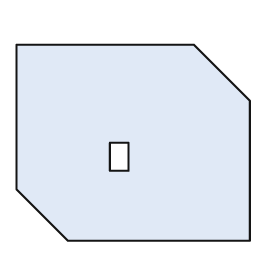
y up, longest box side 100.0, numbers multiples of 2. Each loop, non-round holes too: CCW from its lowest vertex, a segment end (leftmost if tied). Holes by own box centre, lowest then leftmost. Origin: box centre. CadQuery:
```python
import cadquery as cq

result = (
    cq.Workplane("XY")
    .moveTo(-28.0, -42.0)
    .lineTo(50.0, -42.0)
    .lineTo(50.0, 18.0)
    .lineTo(26.0, 42.0)
    .lineTo(-50.0, 42.0)
    .lineTo(-50.0, -20.0)
    .close()
    .moveTo(-10.0, -12.0)
    .lineTo(-2.0, -12.0)
    .lineTo(-2.0, 0.0)
    .lineTo(-10.0, 0.0)
    .close()
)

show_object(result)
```